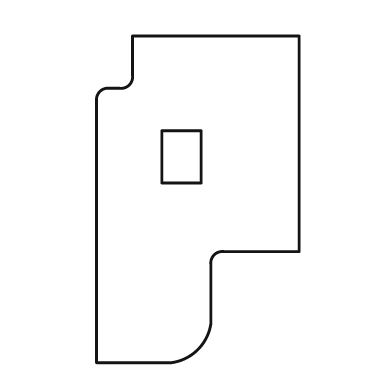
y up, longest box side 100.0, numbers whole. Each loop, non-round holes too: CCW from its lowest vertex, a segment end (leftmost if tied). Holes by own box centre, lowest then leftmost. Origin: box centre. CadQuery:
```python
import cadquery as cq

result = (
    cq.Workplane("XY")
    .moveTo(-31.0, -50.0)
    .lineTo(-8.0, -50.0)
    .threePointArc((0.0, -46.0), (4.0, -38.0))
    .lineTo(4.0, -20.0)
    .threePointArc((5.0, -17.0), (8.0, -16.0))
    .lineTo(31.0, -16.0)
    .lineTo(31.0, 50.0)
    .lineTo(-20.0, 50.0)
    .lineTo(-20.0, 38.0)
    .threePointArc((-21.0, 35.0), (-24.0, 34.0))
    .lineTo(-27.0, 34.0)
    .threePointArc((-30.0, 33.0), (-31.0, 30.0))
    .close()
    .moveTo(-11.0, 5.0)
    .lineTo(1.0, 5.0)
    .lineTo(1.0, 21.0)
    .lineTo(-11.0, 21.0)
    .close()
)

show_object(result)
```